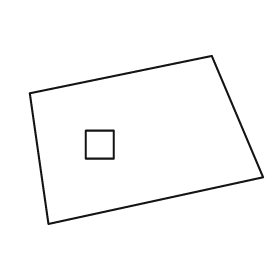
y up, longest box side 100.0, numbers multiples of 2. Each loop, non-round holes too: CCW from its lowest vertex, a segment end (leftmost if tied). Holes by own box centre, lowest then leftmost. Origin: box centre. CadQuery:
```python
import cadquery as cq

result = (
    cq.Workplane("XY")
    .moveTo(-42.0, -36.0)
    .lineTo(50.0, -16.0)
    .lineTo(28.0, 36.0)
    .lineTo(-50.0, 20.0)
    .close()
    .moveTo(-26.0, -8.0)
    .lineTo(-14.0, -8.0)
    .lineTo(-14.0, 4.0)
    .lineTo(-26.0, 4.0)
    .close()
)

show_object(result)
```